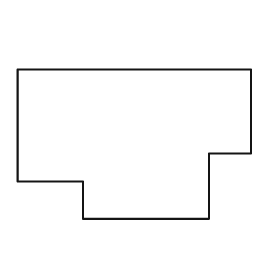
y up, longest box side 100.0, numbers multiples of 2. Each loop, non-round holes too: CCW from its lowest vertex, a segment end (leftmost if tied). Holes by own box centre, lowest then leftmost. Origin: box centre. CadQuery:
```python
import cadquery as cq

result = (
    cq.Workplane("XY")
    .moveTo(-22.0, -32.0)
    .lineTo(32.0, -32.0)
    .lineTo(32.0, -4.0)
    .lineTo(50.0, -4.0)
    .lineTo(50.0, 32.0)
    .lineTo(-50.0, 32.0)
    .lineTo(-50.0, -16.0)
    .lineTo(-22.0, -16.0)
    .close()
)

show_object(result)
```